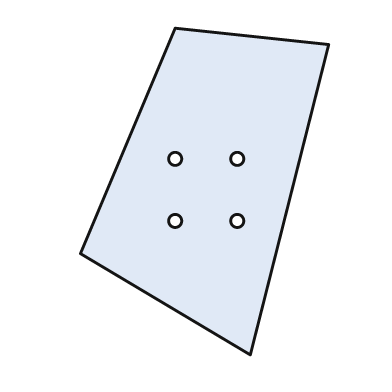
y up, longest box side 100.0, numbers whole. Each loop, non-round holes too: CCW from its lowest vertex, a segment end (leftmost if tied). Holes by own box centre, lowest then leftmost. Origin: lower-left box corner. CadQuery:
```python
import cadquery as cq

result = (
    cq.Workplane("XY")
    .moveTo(52.0, 0.0)
    .lineTo(76.0, 95.0)
    .lineTo(29.0, 100.0)
    .lineTo(0.0, 31.0)
    .close()
    .moveTo(29.0, 41.0)
    .circle(2.0)
    .moveTo(48.0, 41.0)
    .circle(2.0)
    .moveTo(29.0, 60.0)
    .circle(2.0)
    .moveTo(48.0, 60.0)
    .circle(2.0)
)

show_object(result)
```